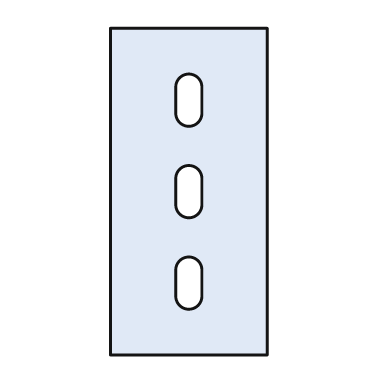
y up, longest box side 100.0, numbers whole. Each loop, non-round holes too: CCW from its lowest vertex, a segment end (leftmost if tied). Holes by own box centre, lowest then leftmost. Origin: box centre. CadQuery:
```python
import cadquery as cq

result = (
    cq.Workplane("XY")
    .moveTo(-24.0, -50.0)
    .lineTo(24.0, -50.0)
    .lineTo(24.0, 50.0)
    .lineTo(-24.0, 50.0)
    .close()
    .moveTo(-4.0, -32.0)
    .threePointArc((0.0, -36.0), (4.0, -32.0))
    .lineTo(4.0, -24.0)
    .threePointArc((0.0, -20.0), (-4.0, -24.0))
    .close()
    .moveTo(-4.0, -4.0)
    .threePointArc((0.0, -8.0), (4.0, -4.0))
    .lineTo(4.0, 4.0)
    .threePointArc((0.0, 8.0), (-4.0, 4.0))
    .close()
    .moveTo(-4.0, 24.0)
    .threePointArc((0.0, 20.0), (4.0, 24.0))
    .lineTo(4.0, 32.0)
    .threePointArc((0.0, 36.0), (-4.0, 32.0))
    .close()
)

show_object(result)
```